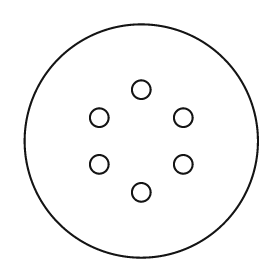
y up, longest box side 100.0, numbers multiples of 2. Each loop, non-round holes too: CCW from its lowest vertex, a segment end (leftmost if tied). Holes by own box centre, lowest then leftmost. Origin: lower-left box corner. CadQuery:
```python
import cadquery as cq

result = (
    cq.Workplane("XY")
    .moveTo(50.0, 50.0)
    .circle(50.0)
    .moveTo(50.0, 28.0)
    .circle(4.0)
    .moveTo(32.0, 40.0)
    .circle(4.0)
    .moveTo(68.0, 40.0)
    .circle(4.0)
    .moveTo(32.0, 60.0)
    .circle(4.0)
    .moveTo(68.0, 60.0)
    .circle(4.0)
    .moveTo(50.0, 72.0)
    .circle(4.0)
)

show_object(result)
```